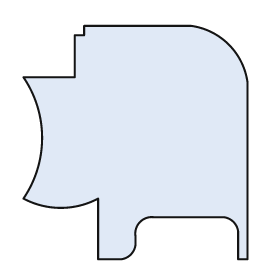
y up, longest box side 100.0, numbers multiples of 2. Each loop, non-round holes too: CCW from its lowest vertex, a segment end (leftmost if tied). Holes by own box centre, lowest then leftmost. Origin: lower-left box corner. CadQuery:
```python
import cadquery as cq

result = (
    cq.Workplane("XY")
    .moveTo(32.0, 0.0)
    .lineTo(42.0, 0.0)
    .threePointArc((46.0, 2.0), (48.0, 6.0))
    .lineTo(48.0, 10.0)
    .threePointArc((50.0, 16.0), (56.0, 18.0))
    .lineTo(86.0, 18.0)
    .threePointArc((90.0, 16.0), (92.0, 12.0))
    .lineTo(92.0, 0.0)
    .lineTo(96.0, 0.0)
    .lineTo(96.0, 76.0)
    .threePointArc((88.0, 92.0), (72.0, 100.0))
    .lineTo(26.0, 100.0)
    .lineTo(26.0, 96.0)
    .lineTo(22.0, 96.0)
    .lineTo(22.0, 78.0)
    .lineTo(0.0, 78.0)
    .threePointArc((8.0, 52.0), (0.0, 26.0))
    .threePointArc((16.0, 22.0), (32.0, 26.0))
    .close()
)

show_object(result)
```